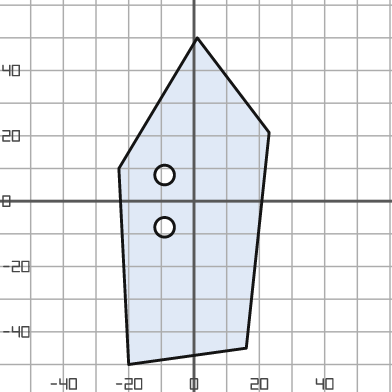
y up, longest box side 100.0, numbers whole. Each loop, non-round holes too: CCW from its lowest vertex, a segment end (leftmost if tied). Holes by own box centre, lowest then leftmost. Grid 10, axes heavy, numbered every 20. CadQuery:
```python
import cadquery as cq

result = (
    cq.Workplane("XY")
    .moveTo(-20.0, -50.0)
    .lineTo(16.0, -45.0)
    .lineTo(23.0, 21.0)
    .lineTo(1.0, 50.0)
    .lineTo(-23.0, 10.0)
    .close()
    .moveTo(-9.0, -8.0)
    .circle(3.0)
    .moveTo(-9.0, 8.0)
    .circle(3.0)
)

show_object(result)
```